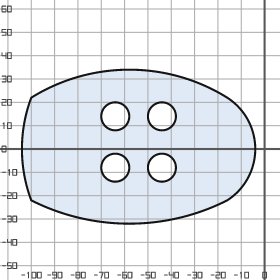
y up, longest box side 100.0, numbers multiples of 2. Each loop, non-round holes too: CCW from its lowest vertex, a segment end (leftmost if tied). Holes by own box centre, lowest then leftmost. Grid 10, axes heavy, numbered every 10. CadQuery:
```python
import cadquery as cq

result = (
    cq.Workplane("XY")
    .moveTo(-100.0, -22.0)
    .threePointArc((-58.0, -32.0), (-16.0, -22.0))
    .threePointArc((-4.0, 0.0), (-16.0, 22.0))
    .threePointArc((-58.0, 34.0), (-100.0, 22.0))
    .threePointArc((-104.0, 0.0), (-100.0, -22.0))
    .close()
    .moveTo(-64.0, -8.0)
    .circle(6.0)
    .moveTo(-44.0, -8.0)
    .circle(6.0)
    .moveTo(-64.0, 14.0)
    .circle(6.0)
    .moveTo(-44.0, 14.0)
    .circle(6.0)
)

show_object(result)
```